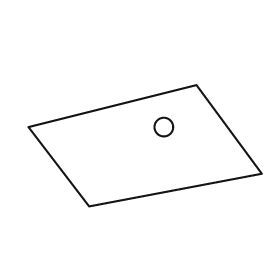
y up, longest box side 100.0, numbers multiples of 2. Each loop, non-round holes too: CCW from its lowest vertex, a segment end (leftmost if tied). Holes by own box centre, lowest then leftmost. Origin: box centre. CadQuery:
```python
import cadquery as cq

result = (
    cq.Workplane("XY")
    .moveTo(-24.0, -26.0)
    .lineTo(50.0, -12.0)
    .lineTo(22.0, 26.0)
    .lineTo(-50.0, 8.0)
    .close()
    .moveTo(8.0, 8.0)
    .circle(4.0)
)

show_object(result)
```